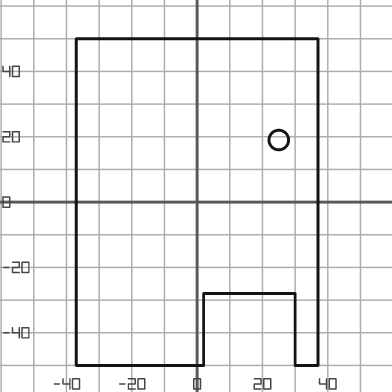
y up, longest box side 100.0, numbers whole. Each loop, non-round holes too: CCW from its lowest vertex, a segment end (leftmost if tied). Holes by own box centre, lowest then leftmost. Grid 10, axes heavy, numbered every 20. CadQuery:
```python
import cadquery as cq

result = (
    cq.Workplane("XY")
    .moveTo(-37.0, -50.0)
    .lineTo(2.0, -50.0)
    .lineTo(2.0, -28.0)
    .lineTo(30.0, -28.0)
    .lineTo(30.0, -50.0)
    .lineTo(37.0, -50.0)
    .lineTo(37.0, 50.0)
    .lineTo(-37.0, 50.0)
    .close()
    .moveTo(25.0, 19.0)
    .circle(3.0)
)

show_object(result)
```